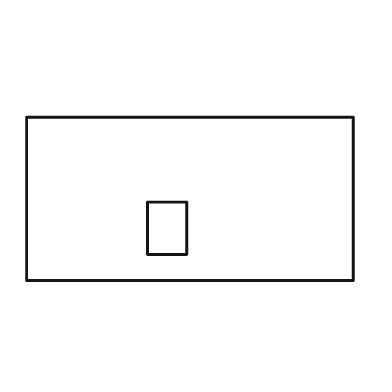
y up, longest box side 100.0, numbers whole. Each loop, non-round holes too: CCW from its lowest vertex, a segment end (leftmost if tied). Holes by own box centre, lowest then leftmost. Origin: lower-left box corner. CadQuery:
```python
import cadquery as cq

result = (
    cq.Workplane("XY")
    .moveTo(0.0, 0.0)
    .lineTo(100.0, 0.0)
    .lineTo(100.0, 50.0)
    .lineTo(0.0, 50.0)
    .close()
    .moveTo(37.0, 8.0)
    .lineTo(49.0, 8.0)
    .lineTo(49.0, 24.0)
    .lineTo(37.0, 24.0)
    .close()
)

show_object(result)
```